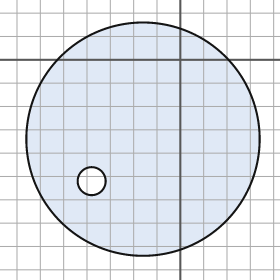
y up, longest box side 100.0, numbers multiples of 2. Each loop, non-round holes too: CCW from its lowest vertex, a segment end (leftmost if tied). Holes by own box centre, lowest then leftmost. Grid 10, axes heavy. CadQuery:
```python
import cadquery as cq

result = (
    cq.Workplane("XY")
    .moveTo(-16.0, -34.0)
    .circle(50.0)
    .moveTo(-38.0, -52.0)
    .circle(6.0)
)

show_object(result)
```